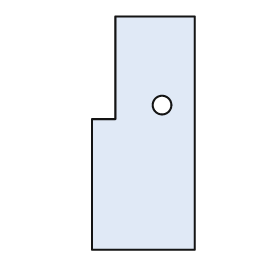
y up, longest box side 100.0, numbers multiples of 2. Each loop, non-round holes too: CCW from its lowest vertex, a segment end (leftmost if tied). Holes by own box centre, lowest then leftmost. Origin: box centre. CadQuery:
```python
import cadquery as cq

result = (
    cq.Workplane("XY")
    .moveTo(-22.0, -50.0)
    .lineTo(22.0, -50.0)
    .lineTo(22.0, 50.0)
    .lineTo(-12.0, 50.0)
    .lineTo(-12.0, 6.0)
    .lineTo(-22.0, 6.0)
    .close()
    .moveTo(8.0, 12.0)
    .circle(4.0)
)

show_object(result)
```